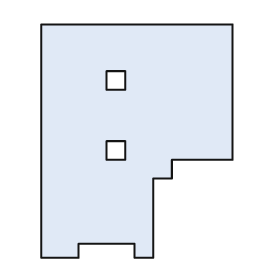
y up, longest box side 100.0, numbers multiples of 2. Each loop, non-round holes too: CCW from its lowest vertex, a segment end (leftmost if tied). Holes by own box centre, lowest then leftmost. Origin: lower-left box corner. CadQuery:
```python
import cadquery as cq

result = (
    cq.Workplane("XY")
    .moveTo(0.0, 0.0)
    .lineTo(16.0, 0.0)
    .lineTo(16.0, 6.0)
    .lineTo(40.0, 6.0)
    .lineTo(40.0, 0.0)
    .lineTo(48.0, 0.0)
    .lineTo(48.0, 34.0)
    .lineTo(56.0, 34.0)
    .lineTo(56.0, 42.0)
    .lineTo(82.0, 42.0)
    .lineTo(82.0, 100.0)
    .lineTo(0.0, 100.0)
    .close()
    .moveTo(28.0, 42.0)
    .lineTo(36.0, 42.0)
    .lineTo(36.0, 50.0)
    .lineTo(28.0, 50.0)
    .close()
    .moveTo(28.0, 72.0)
    .lineTo(36.0, 72.0)
    .lineTo(36.0, 80.0)
    .lineTo(28.0, 80.0)
    .close()
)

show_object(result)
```